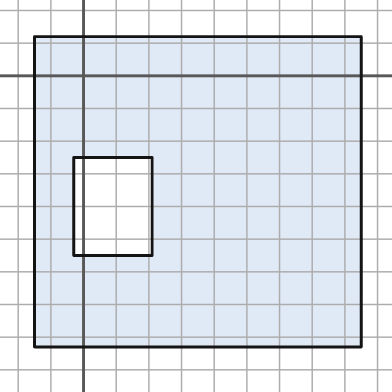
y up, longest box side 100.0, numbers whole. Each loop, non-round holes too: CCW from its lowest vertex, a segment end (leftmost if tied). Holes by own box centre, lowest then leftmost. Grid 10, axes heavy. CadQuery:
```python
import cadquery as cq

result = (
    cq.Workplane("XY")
    .moveTo(-15.0, -83.0)
    .lineTo(85.0, -83.0)
    .lineTo(85.0, 12.0)
    .lineTo(-15.0, 12.0)
    .close()
    .moveTo(-3.0, -55.0)
    .lineTo(21.0, -55.0)
    .lineTo(21.0, -25.0)
    .lineTo(-3.0, -25.0)
    .close()
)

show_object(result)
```